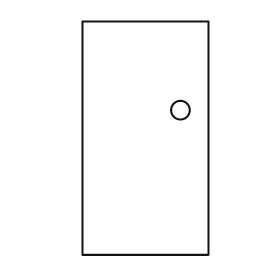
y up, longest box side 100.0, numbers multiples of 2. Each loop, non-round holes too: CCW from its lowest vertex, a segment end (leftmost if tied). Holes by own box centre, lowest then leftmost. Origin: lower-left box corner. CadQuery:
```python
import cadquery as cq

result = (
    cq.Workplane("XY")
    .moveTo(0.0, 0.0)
    .lineTo(54.0, 0.0)
    .lineTo(54.0, 100.0)
    .lineTo(0.0, 100.0)
    .close()
    .moveTo(42.0, 62.0)
    .circle(4.0)
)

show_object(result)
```